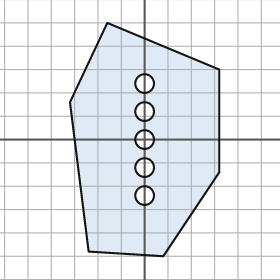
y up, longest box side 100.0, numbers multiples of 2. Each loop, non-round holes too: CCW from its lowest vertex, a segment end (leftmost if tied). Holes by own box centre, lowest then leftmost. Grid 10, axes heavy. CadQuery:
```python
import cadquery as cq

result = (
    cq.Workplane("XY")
    .moveTo(8.0, -50.0)
    .lineTo(32.0, -14.0)
    .lineTo(32.0, 30.0)
    .lineTo(-16.0, 50.0)
    .lineTo(-32.0, 16.0)
    .lineTo(-24.0, -48.0)
    .close()
    .moveTo(0.0, -24.0)
    .circle(4.0)
    .moveTo(0.0, -12.0)
    .circle(4.0)
    .moveTo(0.0, 0.0)
    .circle(4.0)
    .moveTo(0.0, 12.0)
    .circle(4.0)
    .moveTo(0.0, 24.0)
    .circle(4.0)
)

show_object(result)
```